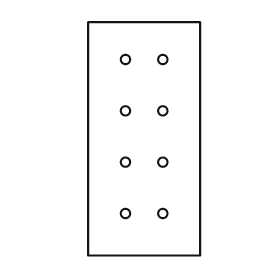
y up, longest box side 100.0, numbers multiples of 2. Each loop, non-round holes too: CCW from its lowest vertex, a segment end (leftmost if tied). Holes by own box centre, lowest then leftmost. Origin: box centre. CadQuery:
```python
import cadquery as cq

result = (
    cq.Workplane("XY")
    .moveTo(-24.0, -50.0)
    .lineTo(24.0, -50.0)
    .lineTo(24.0, 50.0)
    .lineTo(-24.0, 50.0)
    .close()
    .moveTo(-8.0, -32.0)
    .circle(2.0)
    .moveTo(8.0, -32.0)
    .circle(2.0)
    .moveTo(-8.0, -10.0)
    .circle(2.0)
    .moveTo(8.0, -10.0)
    .circle(2.0)
    .moveTo(-8.0, 12.0)
    .circle(2.0)
    .moveTo(8.0, 12.0)
    .circle(2.0)
    .moveTo(-8.0, 34.0)
    .circle(2.0)
    .moveTo(8.0, 34.0)
    .circle(2.0)
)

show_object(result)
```